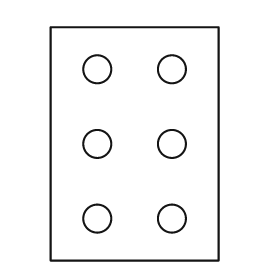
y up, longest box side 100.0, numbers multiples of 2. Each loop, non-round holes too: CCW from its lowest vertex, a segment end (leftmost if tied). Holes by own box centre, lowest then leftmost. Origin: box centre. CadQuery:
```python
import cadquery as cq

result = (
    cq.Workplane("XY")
    .moveTo(-36.0, -50.0)
    .lineTo(36.0, -50.0)
    .lineTo(36.0, 50.0)
    .lineTo(-36.0, 50.0)
    .close()
    .moveTo(-16.0, -32.0)
    .circle(6.0)
    .moveTo(16.0, -32.0)
    .circle(6.0)
    .moveTo(-16.0, 0.0)
    .circle(6.0)
    .moveTo(16.0, 0.0)
    .circle(6.0)
    .moveTo(-16.0, 32.0)
    .circle(6.0)
    .moveTo(16.0, 32.0)
    .circle(6.0)
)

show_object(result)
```